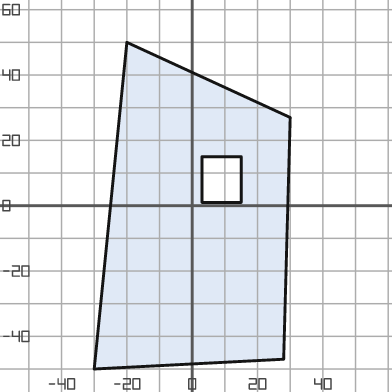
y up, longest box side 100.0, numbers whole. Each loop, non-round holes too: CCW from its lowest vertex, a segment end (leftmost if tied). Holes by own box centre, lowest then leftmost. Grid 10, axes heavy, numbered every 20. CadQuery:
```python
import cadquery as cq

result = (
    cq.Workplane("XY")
    .moveTo(-30.0, -50.0)
    .lineTo(28.0, -47.0)
    .lineTo(30.0, 27.0)
    .lineTo(-20.0, 50.0)
    .close()
    .moveTo(3.0, 1.0)
    .lineTo(15.0, 1.0)
    .lineTo(15.0, 15.0)
    .lineTo(3.0, 15.0)
    .close()
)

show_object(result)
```